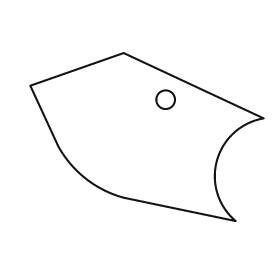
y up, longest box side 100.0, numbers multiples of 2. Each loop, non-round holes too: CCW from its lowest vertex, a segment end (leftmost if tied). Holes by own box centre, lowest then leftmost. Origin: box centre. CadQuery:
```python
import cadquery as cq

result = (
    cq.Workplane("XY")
    .moveTo(38.0, -36.0)
    .threePointArc((30.0, -10.0), (50.0, 8.0))
    .lineTo(-10.0, 36.0)
    .lineTo(-50.0, 22.0)
    .lineTo(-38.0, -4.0)
    .threePointArc((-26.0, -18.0), (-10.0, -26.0))
    .close()
    .moveTo(8.0, 16.0)
    .circle(4.0)
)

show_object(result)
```